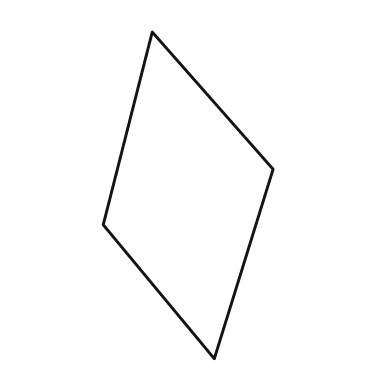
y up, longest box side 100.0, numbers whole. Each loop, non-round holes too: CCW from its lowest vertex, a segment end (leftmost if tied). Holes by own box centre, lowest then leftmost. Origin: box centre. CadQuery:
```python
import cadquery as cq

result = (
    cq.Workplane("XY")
    .moveTo(8.0, -50.0)
    .lineTo(26.0, 8.0)
    .lineTo(-11.0, 50.0)
    .lineTo(-26.0, -9.0)
    .close()
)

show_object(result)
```